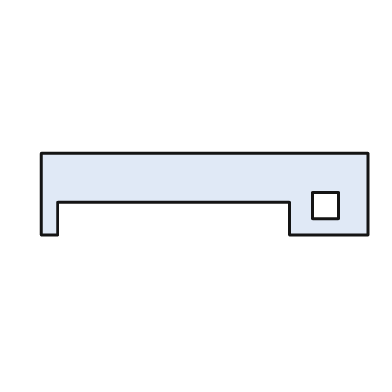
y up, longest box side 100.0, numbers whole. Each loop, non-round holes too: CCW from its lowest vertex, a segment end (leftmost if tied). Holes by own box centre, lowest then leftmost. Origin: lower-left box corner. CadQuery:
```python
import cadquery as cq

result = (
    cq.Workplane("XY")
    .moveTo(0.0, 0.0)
    .lineTo(5.0, 0.0)
    .lineTo(5.0, 10.0)
    .lineTo(76.0, 10.0)
    .lineTo(76.0, 0.0)
    .lineTo(100.0, 0.0)
    .lineTo(100.0, 25.0)
    .lineTo(0.0, 25.0)
    .close()
    .moveTo(83.0, 5.0)
    .lineTo(91.0, 5.0)
    .lineTo(91.0, 13.0)
    .lineTo(83.0, 13.0)
    .close()
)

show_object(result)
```